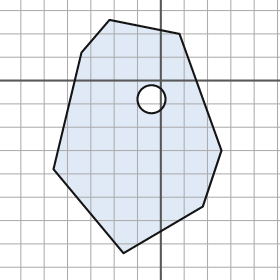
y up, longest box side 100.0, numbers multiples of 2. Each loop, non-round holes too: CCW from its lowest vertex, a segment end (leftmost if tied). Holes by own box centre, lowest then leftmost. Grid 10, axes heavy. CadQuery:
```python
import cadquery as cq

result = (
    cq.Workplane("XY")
    .moveTo(-16.0, -74.0)
    .lineTo(18.0, -54.0)
    .lineTo(26.0, -30.0)
    .lineTo(8.0, 20.0)
    .lineTo(-22.0, 26.0)
    .lineTo(-34.0, 12.0)
    .lineTo(-46.0, -38.0)
    .close()
    .moveTo(-4.0, -8.0)
    .circle(6.0)
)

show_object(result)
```